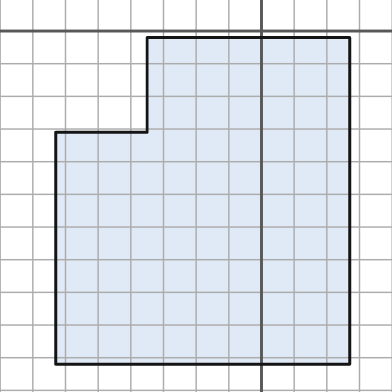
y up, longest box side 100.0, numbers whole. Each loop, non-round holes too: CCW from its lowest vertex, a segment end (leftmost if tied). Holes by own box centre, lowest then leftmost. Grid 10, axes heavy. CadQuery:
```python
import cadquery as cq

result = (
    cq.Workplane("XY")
    .moveTo(-63.0, -102.0)
    .lineTo(27.0, -102.0)
    .lineTo(27.0, -2.0)
    .lineTo(-35.0, -2.0)
    .lineTo(-35.0, -31.0)
    .lineTo(-63.0, -31.0)
    .close()
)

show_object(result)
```